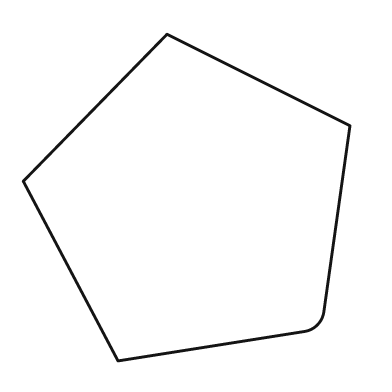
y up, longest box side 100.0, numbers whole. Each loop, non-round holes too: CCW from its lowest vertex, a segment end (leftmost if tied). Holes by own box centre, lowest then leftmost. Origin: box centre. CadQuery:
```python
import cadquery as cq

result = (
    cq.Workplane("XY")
    .moveTo(-21.0, -50.0)
    .lineTo(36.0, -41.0)
    .threePointArc((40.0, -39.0), (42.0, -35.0))
    .lineTo(50.0, 22.0)
    .lineTo(-6.0, 50.0)
    .lineTo(-50.0, 5.0)
    .close()
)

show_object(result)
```